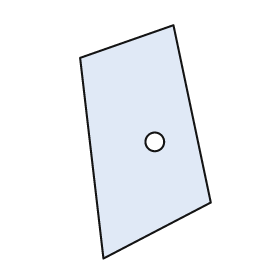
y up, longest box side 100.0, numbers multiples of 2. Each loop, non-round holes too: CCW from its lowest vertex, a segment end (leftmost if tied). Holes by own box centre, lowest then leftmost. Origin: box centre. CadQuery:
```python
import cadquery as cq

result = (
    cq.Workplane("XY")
    .moveTo(-18.0, -50.0)
    .lineTo(28.0, -26.0)
    .lineTo(12.0, 50.0)
    .lineTo(-28.0, 36.0)
    .close()
    .moveTo(4.0, 0.0)
    .circle(4.0)
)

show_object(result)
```